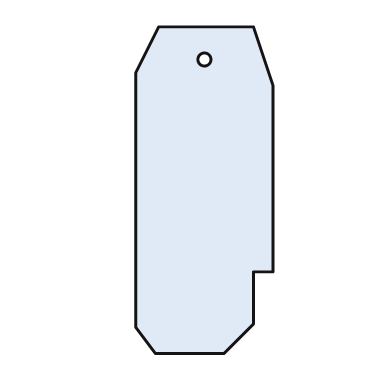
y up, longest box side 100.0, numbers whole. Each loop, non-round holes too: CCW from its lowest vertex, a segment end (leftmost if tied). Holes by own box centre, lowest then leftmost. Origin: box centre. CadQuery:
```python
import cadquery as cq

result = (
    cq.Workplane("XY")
    .moveTo(-15.0, -50.0)
    .lineTo(6.0, -50.0)
    .lineTo(15.0, -41.0)
    .lineTo(15.0, -25.0)
    .lineTo(21.0, -25.0)
    .lineTo(21.0, 32.0)
    .lineTo(15.0, 50.0)
    .lineTo(-14.0, 50.0)
    .lineTo(-21.0, 36.0)
    .lineTo(-21.0, -42.0)
    .close()
    .moveTo(0.0, 40.0)
    .circle(2.0)
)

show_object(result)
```